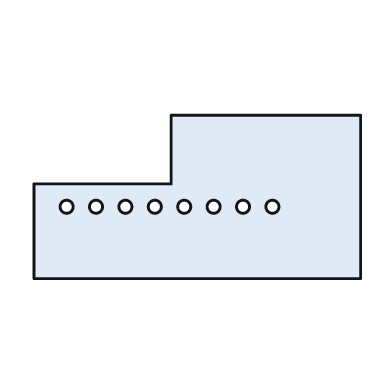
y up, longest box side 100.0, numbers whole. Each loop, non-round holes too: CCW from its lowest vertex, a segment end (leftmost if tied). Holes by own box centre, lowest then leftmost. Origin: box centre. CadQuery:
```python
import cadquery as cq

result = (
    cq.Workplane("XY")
    .moveTo(-50.0, -25.0)
    .lineTo(50.0, -25.0)
    .lineTo(50.0, 25.0)
    .lineTo(-8.0, 25.0)
    .lineTo(-8.0, 4.0)
    .lineTo(-50.0, 4.0)
    .close()
    .moveTo(-40.0, -3.0)
    .circle(2.0)
    .moveTo(-31.0, -3.0)
    .circle(2.0)
    .moveTo(-22.0, -3.0)
    .circle(2.0)
    .moveTo(-13.0, -3.0)
    .circle(2.0)
    .moveTo(-4.0, -3.0)
    .circle(2.0)
    .moveTo(5.0, -3.0)
    .circle(2.0)
    .moveTo(14.0, -3.0)
    .circle(2.0)
    .moveTo(23.0, -3.0)
    .circle(2.0)
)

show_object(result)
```